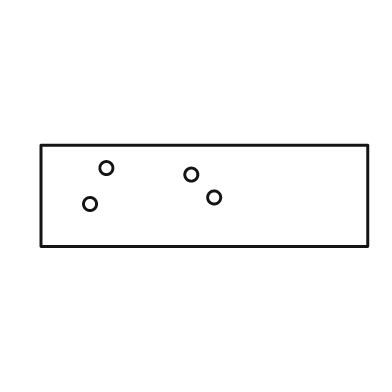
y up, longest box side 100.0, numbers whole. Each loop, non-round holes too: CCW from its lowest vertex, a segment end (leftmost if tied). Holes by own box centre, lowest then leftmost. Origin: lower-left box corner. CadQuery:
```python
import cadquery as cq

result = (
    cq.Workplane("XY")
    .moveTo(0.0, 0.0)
    .lineTo(100.0, 0.0)
    .lineTo(100.0, 31.0)
    .lineTo(0.0, 31.0)
    .close()
    .moveTo(15.0, 13.0)
    .circle(2.0)
    .moveTo(53.0, 15.0)
    .circle(2.0)
    .moveTo(46.0, 22.0)
    .circle(2.0)
    .moveTo(20.0, 24.0)
    .circle(2.0)
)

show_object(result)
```